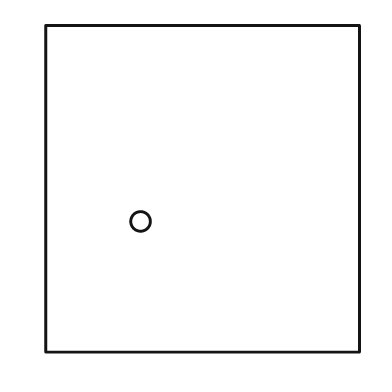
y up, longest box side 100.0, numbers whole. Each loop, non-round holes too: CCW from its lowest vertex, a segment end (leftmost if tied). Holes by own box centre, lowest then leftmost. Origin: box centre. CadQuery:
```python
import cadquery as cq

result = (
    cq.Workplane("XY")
    .moveTo(-48.0, -50.0)
    .lineTo(48.0, -50.0)
    .lineTo(48.0, 50.0)
    .lineTo(-48.0, 50.0)
    .close()
    .moveTo(-19.0, -10.0)
    .circle(3.0)
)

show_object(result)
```